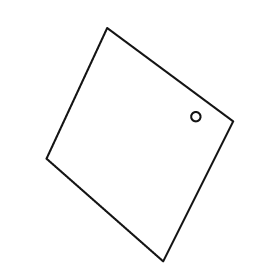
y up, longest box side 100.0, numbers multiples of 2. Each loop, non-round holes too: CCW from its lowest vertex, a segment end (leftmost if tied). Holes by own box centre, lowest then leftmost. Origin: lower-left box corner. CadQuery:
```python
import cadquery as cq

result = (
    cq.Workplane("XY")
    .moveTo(50.0, 0.0)
    .lineTo(80.0, 60.0)
    .lineTo(26.0, 100.0)
    .lineTo(0.0, 44.0)
    .close()
    .moveTo(64.0, 62.0)
    .circle(2.0)
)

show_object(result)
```